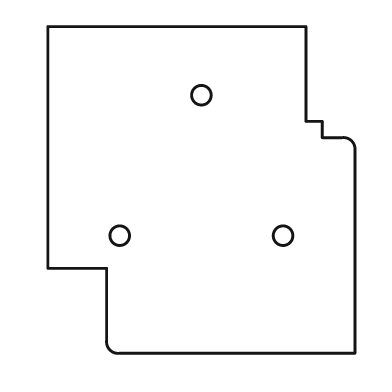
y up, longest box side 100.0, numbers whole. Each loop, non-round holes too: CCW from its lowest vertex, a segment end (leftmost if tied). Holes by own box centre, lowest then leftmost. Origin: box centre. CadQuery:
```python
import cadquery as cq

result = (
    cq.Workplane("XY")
    .moveTo(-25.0, -50.0)
    .lineTo(47.0, -50.0)
    .lineTo(47.0, 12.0)
    .threePointArc((46.0, 15.0), (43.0, 16.0))
    .lineTo(37.0, 16.0)
    .lineTo(37.0, 21.0)
    .lineTo(32.0, 21.0)
    .lineTo(32.0, 50.0)
    .lineTo(-47.0, 50.0)
    .lineTo(-47.0, -24.0)
    .lineTo(-29.0, -24.0)
    .lineTo(-29.0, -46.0)
    .threePointArc((-28.0, -49.0), (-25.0, -50.0))
    .close()
    .moveTo(-25.0, -14.0)
    .circle(3.0)
    .moveTo(25.0, -14.0)
    .circle(3.0)
    .moveTo(0.0, 29.0)
    .circle(3.0)
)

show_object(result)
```